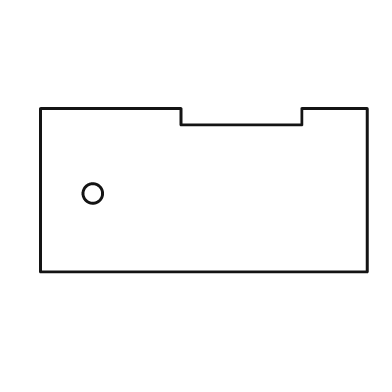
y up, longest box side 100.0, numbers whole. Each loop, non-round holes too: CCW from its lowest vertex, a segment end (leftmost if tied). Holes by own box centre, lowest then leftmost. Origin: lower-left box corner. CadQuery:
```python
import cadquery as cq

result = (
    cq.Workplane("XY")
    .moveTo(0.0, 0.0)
    .lineTo(100.0, 0.0)
    .lineTo(100.0, 50.0)
    .lineTo(80.0, 50.0)
    .lineTo(80.0, 45.0)
    .lineTo(43.0, 45.0)
    .lineTo(43.0, 50.0)
    .lineTo(0.0, 50.0)
    .close()
    .moveTo(16.0, 24.0)
    .circle(3.0)
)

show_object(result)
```